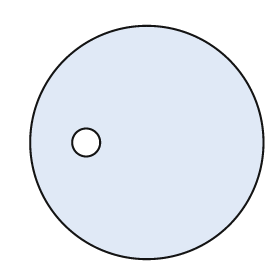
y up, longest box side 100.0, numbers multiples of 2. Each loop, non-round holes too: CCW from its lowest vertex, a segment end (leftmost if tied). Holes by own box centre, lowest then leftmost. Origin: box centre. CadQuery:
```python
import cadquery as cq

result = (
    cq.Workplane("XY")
    .moveTo(0.0, 0.0)
    .circle(50.0)
    .moveTo(-26.0, 0.0)
    .circle(6.0)
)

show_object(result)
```